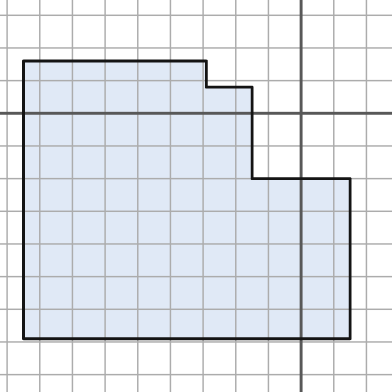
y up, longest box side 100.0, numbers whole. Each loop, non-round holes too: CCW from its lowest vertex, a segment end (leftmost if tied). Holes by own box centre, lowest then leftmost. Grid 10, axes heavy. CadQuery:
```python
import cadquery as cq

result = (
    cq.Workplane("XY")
    .moveTo(-85.0, -69.0)
    .lineTo(15.0, -69.0)
    .lineTo(15.0, -20.0)
    .lineTo(-15.0, -20.0)
    .lineTo(-15.0, 8.0)
    .lineTo(-29.0, 8.0)
    .lineTo(-29.0, 16.0)
    .lineTo(-85.0, 16.0)
    .close()
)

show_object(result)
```